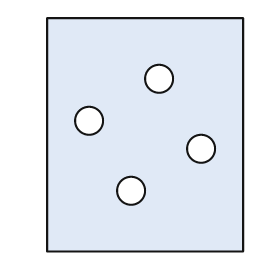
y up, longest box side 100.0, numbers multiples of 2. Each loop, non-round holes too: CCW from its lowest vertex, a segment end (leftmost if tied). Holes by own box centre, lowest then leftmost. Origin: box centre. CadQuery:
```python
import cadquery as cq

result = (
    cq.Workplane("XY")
    .moveTo(-42.0, -50.0)
    .lineTo(42.0, -50.0)
    .lineTo(42.0, 50.0)
    .lineTo(-42.0, 50.0)
    .close()
    .moveTo(-6.0, -24.0)
    .circle(6.0)
    .moveTo(24.0, -6.0)
    .circle(6.0)
    .moveTo(-24.0, 6.0)
    .circle(6.0)
    .moveTo(6.0, 24.0)
    .circle(6.0)
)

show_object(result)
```